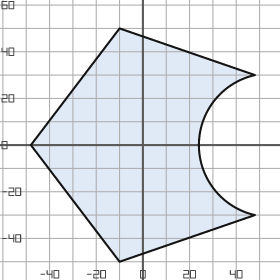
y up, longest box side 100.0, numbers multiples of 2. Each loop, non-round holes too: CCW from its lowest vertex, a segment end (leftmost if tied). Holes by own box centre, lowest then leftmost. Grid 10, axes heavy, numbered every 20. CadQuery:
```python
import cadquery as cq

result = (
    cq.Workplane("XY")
    .moveTo(-10.0, -50.0)
    .lineTo(48.0, -30.0)
    .threePointArc((24.0, 0.0), (48.0, 30.0))
    .lineTo(-10.0, 50.0)
    .lineTo(-48.0, 0.0)
    .close()
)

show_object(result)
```